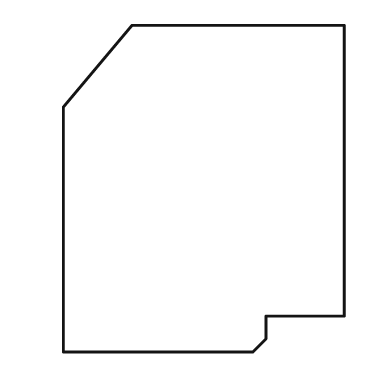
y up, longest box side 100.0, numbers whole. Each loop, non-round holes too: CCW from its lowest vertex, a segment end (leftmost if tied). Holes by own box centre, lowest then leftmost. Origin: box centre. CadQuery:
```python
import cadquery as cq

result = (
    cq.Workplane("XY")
    .moveTo(-43.0, -50.0)
    .lineTo(15.0, -50.0)
    .lineTo(19.0, -46.0)
    .lineTo(19.0, -39.0)
    .lineTo(43.0, -39.0)
    .lineTo(43.0, 50.0)
    .lineTo(-22.0, 50.0)
    .lineTo(-43.0, 25.0)
    .close()
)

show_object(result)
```